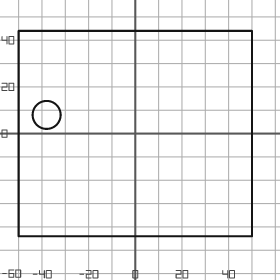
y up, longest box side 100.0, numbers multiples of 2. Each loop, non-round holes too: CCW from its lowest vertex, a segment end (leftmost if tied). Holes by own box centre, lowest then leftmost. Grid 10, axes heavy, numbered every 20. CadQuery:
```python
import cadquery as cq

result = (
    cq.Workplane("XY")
    .moveTo(-50.0, -44.0)
    .lineTo(50.0, -44.0)
    .lineTo(50.0, 44.0)
    .lineTo(-50.0, 44.0)
    .close()
    .moveTo(-38.0, 8.0)
    .circle(6.0)
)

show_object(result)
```